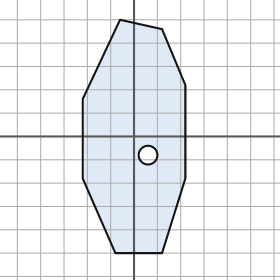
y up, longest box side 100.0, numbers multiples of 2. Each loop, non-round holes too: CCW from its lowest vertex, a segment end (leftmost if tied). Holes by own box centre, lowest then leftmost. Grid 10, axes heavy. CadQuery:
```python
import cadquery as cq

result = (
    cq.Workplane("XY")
    .moveTo(-8.0, -50.0)
    .lineTo(12.0, -50.0)
    .lineTo(22.0, -18.0)
    .lineTo(22.0, 22.0)
    .lineTo(12.0, 46.0)
    .lineTo(-6.0, 50.0)
    .lineTo(-22.0, 16.0)
    .lineTo(-22.0, -18.0)
    .close()
    .moveTo(6.0, -8.0)
    .circle(4.0)
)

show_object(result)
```